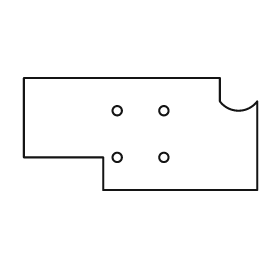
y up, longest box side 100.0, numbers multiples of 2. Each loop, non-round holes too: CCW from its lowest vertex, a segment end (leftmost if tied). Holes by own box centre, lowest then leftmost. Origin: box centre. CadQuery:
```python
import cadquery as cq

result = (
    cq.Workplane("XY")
    .moveTo(-16.0, -24.0)
    .lineTo(50.0, -24.0)
    .lineTo(50.0, 14.0)
    .threePointArc((42.0, 10.0), (34.0, 14.0))
    .lineTo(34.0, 24.0)
    .lineTo(-50.0, 24.0)
    .lineTo(-50.0, -10.0)
    .lineTo(-16.0, -10.0)
    .close()
    .moveTo(-10.0, -10.0)
    .circle(2.0)
    .moveTo(10.0, -10.0)
    .circle(2.0)
    .moveTo(-10.0, 10.0)
    .circle(2.0)
    .moveTo(10.0, 10.0)
    .circle(2.0)
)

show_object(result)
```